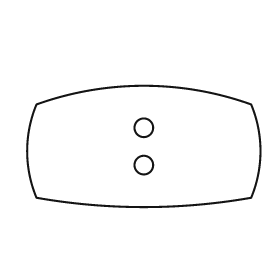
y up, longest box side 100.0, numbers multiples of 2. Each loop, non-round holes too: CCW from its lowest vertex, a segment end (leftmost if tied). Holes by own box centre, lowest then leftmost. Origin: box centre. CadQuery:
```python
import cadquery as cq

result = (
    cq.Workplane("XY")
    .moveTo(-46.0, -22.0)
    .threePointArc((0.0, -26.0), (46.0, -22.0))
    .threePointArc((50.0, -2.0), (46.0, 18.0))
    .threePointArc((0.0, 26.0), (-46.0, 18.0))
    .threePointArc((-50.0, -2.0), (-46.0, -22.0))
    .close()
    .moveTo(0.0, -8.0)
    .circle(4.0)
    .moveTo(0.0, 8.0)
    .circle(4.0)
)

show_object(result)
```